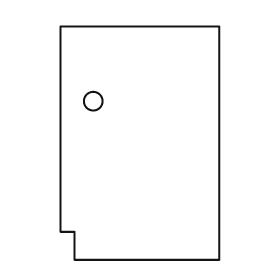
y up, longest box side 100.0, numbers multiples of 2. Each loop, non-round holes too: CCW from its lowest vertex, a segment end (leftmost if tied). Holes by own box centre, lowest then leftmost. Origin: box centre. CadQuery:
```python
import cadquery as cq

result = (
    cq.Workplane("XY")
    .moveTo(-28.0, -50.0)
    .lineTo(34.0, -50.0)
    .lineTo(34.0, 50.0)
    .lineTo(-34.0, 50.0)
    .lineTo(-34.0, -38.0)
    .lineTo(-28.0, -38.0)
    .close()
    .moveTo(-20.0, 18.0)
    .circle(4.0)
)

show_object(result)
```